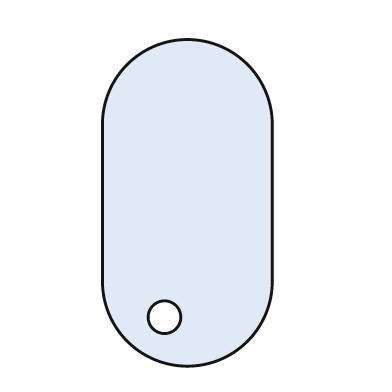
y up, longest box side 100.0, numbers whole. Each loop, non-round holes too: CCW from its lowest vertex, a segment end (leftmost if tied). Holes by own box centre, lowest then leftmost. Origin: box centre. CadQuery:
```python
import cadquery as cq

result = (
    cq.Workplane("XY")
    .moveTo(-26.0, -24.0)
    .threePointArc((0.0, -50.0), (26.0, -24.0))
    .lineTo(26.0, 24.0)
    .threePointArc((0.0, 50.0), (-26.0, 24.0))
    .close()
    .moveTo(-7.0, -35.0)
    .circle(5.0)
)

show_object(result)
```